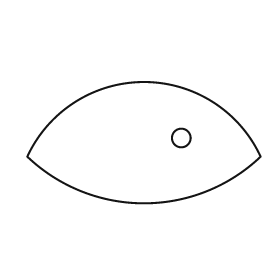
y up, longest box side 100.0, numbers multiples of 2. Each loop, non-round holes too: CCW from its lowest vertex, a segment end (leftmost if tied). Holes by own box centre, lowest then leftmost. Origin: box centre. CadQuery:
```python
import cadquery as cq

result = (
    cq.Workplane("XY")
    .moveTo(-50.0, -6.0)
    .threePointArc((0.0, -26.0), (50.0, -6.0))
    .threePointArc((0.0, 26.0), (-50.0, -6.0))
    .close()
    .moveTo(16.0, 2.0)
    .circle(4.0)
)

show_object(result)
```